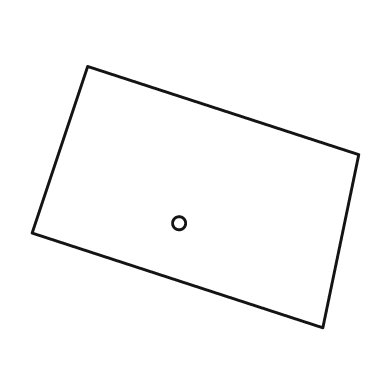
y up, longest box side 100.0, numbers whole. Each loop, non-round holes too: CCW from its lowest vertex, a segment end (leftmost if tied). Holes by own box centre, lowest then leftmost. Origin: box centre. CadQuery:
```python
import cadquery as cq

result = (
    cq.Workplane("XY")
    .moveTo(39.0, -40.0)
    .lineTo(50.0, 13.0)
    .lineTo(-33.0, 40.0)
    .lineTo(-50.0, -11.0)
    .close()
    .moveTo(-5.0, -8.0)
    .circle(2.0)
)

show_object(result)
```